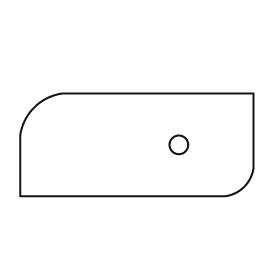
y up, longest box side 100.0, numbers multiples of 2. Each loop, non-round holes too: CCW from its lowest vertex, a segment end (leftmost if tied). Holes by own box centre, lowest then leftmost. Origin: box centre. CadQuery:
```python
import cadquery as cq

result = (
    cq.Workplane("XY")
    .moveTo(-50.0, -22.0)
    .lineTo(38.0, -22.0)
    .threePointArc((46.0, -18.0), (50.0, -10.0))
    .lineTo(50.0, 22.0)
    .lineTo(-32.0, 22.0)
    .threePointArc((-44.0, 16.0), (-50.0, 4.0))
    .close()
    .moveTo(18.0, 0.0)
    .circle(4.0)
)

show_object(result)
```